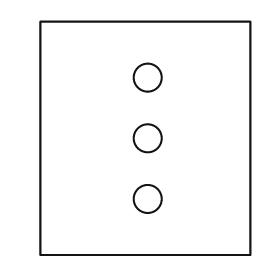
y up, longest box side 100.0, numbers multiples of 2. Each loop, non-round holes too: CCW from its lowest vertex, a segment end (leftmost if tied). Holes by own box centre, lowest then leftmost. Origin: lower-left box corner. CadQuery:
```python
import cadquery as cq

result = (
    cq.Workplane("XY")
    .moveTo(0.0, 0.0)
    .lineTo(90.0, 0.0)
    .lineTo(90.0, 100.0)
    .lineTo(0.0, 100.0)
    .close()
    .moveTo(46.0, 24.0)
    .circle(6.0)
    .moveTo(46.0, 50.0)
    .circle(6.0)
    .moveTo(46.0, 76.0)
    .circle(6.0)
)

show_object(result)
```